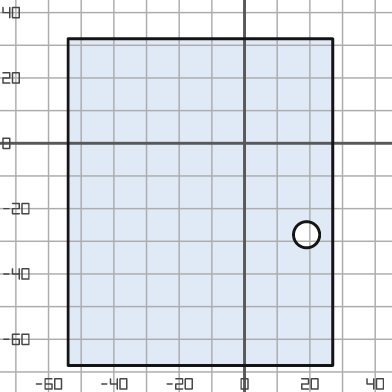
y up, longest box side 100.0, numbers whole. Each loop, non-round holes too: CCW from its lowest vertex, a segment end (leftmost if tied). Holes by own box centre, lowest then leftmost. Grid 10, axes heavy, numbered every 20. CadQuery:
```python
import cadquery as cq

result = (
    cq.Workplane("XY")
    .moveTo(-54.0, -68.0)
    .lineTo(27.0, -68.0)
    .lineTo(27.0, 32.0)
    .lineTo(-54.0, 32.0)
    .close()
    .moveTo(19.0, -28.0)
    .circle(4.0)
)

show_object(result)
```